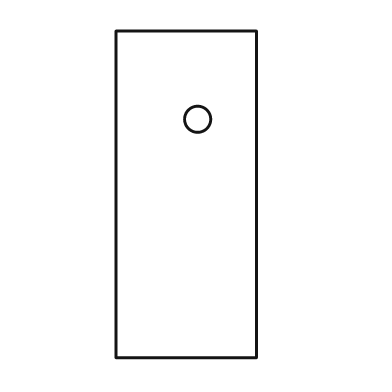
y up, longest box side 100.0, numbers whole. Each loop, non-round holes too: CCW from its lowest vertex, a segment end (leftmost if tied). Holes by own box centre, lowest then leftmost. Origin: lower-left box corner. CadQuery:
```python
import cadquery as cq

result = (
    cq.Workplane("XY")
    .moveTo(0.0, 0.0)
    .lineTo(43.0, 0.0)
    .lineTo(43.0, 100.0)
    .lineTo(0.0, 100.0)
    .close()
    .moveTo(25.0, 73.0)
    .circle(4.0)
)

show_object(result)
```